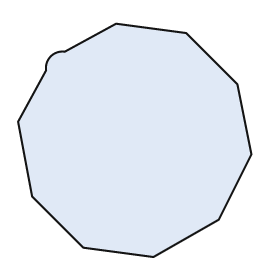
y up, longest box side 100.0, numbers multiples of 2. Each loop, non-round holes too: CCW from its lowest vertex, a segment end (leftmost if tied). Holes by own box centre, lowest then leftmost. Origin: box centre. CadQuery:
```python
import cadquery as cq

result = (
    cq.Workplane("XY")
    .moveTo(8.0, -50.0)
    .lineTo(36.0, -34.0)
    .lineTo(50.0, -6.0)
    .lineTo(44.0, 24.0)
    .lineTo(22.0, 46.0)
    .lineTo(-8.0, 50.0)
    .lineTo(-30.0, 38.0)
    .threePointArc((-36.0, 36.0), (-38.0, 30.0))
    .lineTo(-50.0, 8.0)
    .lineTo(-44.0, -24.0)
    .lineTo(-22.0, -46.0)
    .close()
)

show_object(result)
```